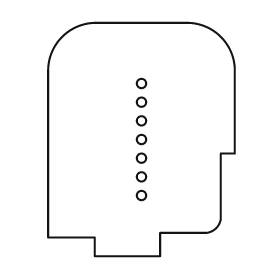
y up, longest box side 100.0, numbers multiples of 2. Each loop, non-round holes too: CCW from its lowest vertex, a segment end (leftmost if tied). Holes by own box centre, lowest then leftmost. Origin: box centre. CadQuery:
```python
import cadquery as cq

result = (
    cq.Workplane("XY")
    .moveTo(-20.0, -50.0)
    .lineTo(8.0, -50.0)
    .lineTo(8.0, -40.0)
    .lineTo(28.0, -40.0)
    .threePointArc((32.0, -38.0), (34.0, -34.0))
    .lineTo(34.0, -6.0)
    .lineTo(40.0, -6.0)
    .lineTo(40.0, 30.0)
    .threePointArc((34.0, 44.0), (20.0, 50.0))
    .lineTo(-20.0, 50.0)
    .threePointArc((-34.0, 44.0), (-40.0, 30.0))
    .lineTo(-40.0, -42.0)
    .lineTo(-20.0, -42.0)
    .close()
    .moveTo(0.0, -24.0)
    .circle(2.0)
    .moveTo(0.0, -16.0)
    .circle(2.0)
    .moveTo(0.0, -8.0)
    .circle(2.0)
    .moveTo(0.0, 0.0)
    .circle(2.0)
    .moveTo(0.0, 8.0)
    .circle(2.0)
    .moveTo(0.0, 16.0)
    .circle(2.0)
    .moveTo(0.0, 24.0)
    .circle(2.0)
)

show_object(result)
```